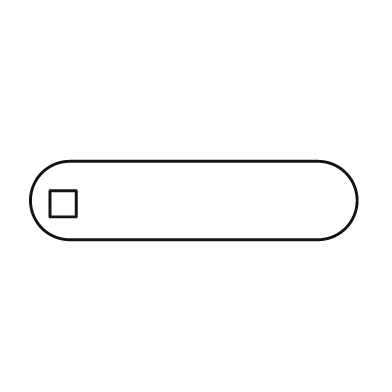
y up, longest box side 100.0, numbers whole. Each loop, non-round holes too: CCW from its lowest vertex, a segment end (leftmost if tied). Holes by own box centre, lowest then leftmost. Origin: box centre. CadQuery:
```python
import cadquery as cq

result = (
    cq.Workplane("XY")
    .moveTo(-38.0, -12.0)
    .lineTo(38.0, -12.0)
    .threePointArc((50.0, 0.0), (38.0, 12.0))
    .lineTo(-38.0, 12.0)
    .threePointArc((-50.0, 0.0), (-38.0, -12.0))
    .close()
    .moveTo(-44.0, -5.0)
    .lineTo(-36.0, -5.0)
    .lineTo(-36.0, 3.0)
    .lineTo(-44.0, 3.0)
    .close()
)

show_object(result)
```